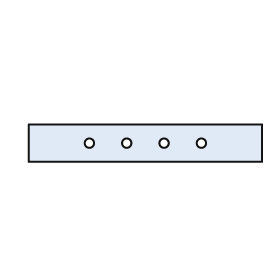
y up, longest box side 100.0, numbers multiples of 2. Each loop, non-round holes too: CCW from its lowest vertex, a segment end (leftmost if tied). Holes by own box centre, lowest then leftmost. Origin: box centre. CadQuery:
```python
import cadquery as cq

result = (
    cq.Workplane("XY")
    .moveTo(-50.0, -8.0)
    .lineTo(50.0, -8.0)
    .lineTo(50.0, 8.0)
    .lineTo(-50.0, 8.0)
    .close()
    .moveTo(-24.0, 0.0)
    .circle(2.0)
    .moveTo(-8.0, 0.0)
    .circle(2.0)
    .moveTo(8.0, 0.0)
    .circle(2.0)
    .moveTo(24.0, 0.0)
    .circle(2.0)
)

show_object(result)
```